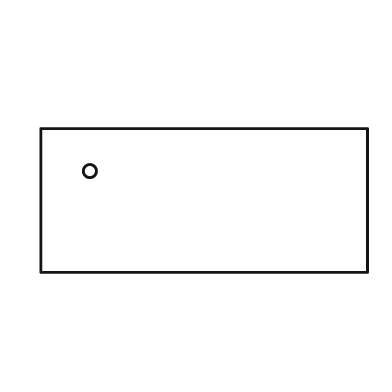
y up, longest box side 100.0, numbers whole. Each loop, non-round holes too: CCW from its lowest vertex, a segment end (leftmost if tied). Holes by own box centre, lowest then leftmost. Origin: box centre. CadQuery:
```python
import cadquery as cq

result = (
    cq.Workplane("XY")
    .moveTo(-50.0, -22.0)
    .lineTo(50.0, -22.0)
    .lineTo(50.0, 22.0)
    .lineTo(-50.0, 22.0)
    .close()
    .moveTo(-35.0, 9.0)
    .circle(2.0)
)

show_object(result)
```